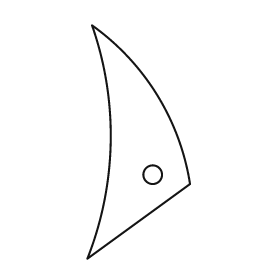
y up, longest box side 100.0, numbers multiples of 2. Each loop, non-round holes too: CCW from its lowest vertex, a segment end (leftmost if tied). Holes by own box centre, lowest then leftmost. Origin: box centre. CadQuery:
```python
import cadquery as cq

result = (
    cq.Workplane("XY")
    .moveTo(-22.0, -50.0)
    .lineTo(22.0, -18.0)
    .threePointArc((8.0, 20.0), (-20.0, 50.0))
    .threePointArc((-12.0, 0.0), (-22.0, -50.0))
    .close()
    .moveTo(6.0, -14.0)
    .circle(4.0)
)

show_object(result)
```